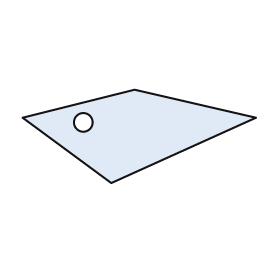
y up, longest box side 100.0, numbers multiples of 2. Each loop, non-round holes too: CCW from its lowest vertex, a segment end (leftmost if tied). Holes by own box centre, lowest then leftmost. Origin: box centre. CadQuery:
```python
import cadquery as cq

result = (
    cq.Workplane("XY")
    .moveTo(-12.0, -20.0)
    .lineTo(50.0, 8.0)
    .lineTo(-2.0, 20.0)
    .lineTo(-50.0, 8.0)
    .close()
    .moveTo(-24.0, 6.0)
    .circle(4.0)
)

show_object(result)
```